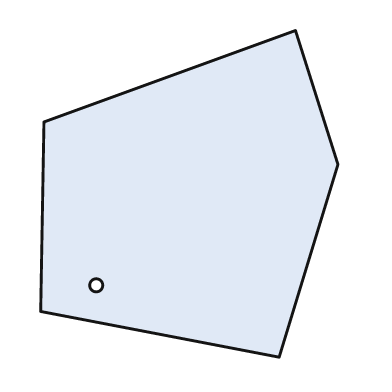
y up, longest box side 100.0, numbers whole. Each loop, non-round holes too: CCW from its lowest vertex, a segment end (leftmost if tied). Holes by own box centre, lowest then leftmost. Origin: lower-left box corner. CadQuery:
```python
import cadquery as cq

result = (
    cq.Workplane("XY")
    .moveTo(73.0, 0.0)
    .lineTo(91.0, 59.0)
    .lineTo(78.0, 100.0)
    .lineTo(1.0, 72.0)
    .lineTo(0.0, 14.0)
    .close()
    .moveTo(17.0, 22.0)
    .circle(2.0)
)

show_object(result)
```